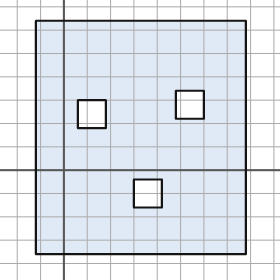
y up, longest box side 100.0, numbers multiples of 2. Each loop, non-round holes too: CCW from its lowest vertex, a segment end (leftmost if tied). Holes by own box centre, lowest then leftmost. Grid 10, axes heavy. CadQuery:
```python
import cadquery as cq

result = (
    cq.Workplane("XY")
    .moveTo(-12.0, -36.0)
    .lineTo(78.0, -36.0)
    .lineTo(78.0, 64.0)
    .lineTo(-12.0, 64.0)
    .close()
    .moveTo(30.0, -16.0)
    .lineTo(42.0, -16.0)
    .lineTo(42.0, -4.0)
    .lineTo(30.0, -4.0)
    .close()
    .moveTo(6.0, 18.0)
    .lineTo(18.0, 18.0)
    .lineTo(18.0, 30.0)
    .lineTo(6.0, 30.0)
    .close()
    .moveTo(48.0, 22.0)
    .lineTo(60.0, 22.0)
    .lineTo(60.0, 34.0)
    .lineTo(48.0, 34.0)
    .close()
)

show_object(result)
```